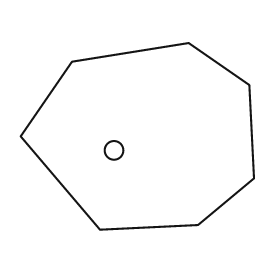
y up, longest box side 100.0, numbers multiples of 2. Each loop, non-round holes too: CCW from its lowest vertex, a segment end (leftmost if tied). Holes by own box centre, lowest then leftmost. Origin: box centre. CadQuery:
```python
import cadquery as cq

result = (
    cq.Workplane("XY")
    .moveTo(-16.0, -40.0)
    .lineTo(26.0, -38.0)
    .lineTo(50.0, -18.0)
    .lineTo(48.0, 22.0)
    .lineTo(22.0, 40.0)
    .lineTo(-28.0, 32.0)
    .lineTo(-50.0, 0.0)
    .close()
    .moveTo(-10.0, -6.0)
    .circle(4.0)
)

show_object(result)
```